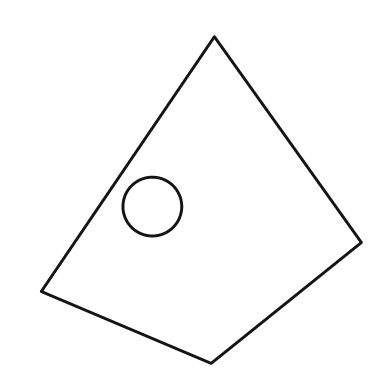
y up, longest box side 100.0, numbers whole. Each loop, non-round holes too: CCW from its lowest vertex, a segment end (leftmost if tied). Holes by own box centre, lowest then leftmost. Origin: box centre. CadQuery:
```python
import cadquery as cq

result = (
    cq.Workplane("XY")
    .moveTo(3.0, -50.0)
    .lineTo(49.0, -13.0)
    .lineTo(4.0, 50.0)
    .lineTo(-49.0, -28.0)
    .close()
    .moveTo(-15.0, -2.0)
    .circle(9.0)
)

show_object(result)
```